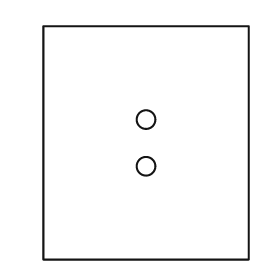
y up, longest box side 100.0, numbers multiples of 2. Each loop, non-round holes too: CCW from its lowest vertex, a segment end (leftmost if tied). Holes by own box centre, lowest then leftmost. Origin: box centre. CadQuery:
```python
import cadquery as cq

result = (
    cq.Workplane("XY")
    .moveTo(-44.0, -50.0)
    .lineTo(44.0, -50.0)
    .lineTo(44.0, 50.0)
    .lineTo(-44.0, 50.0)
    .close()
    .moveTo(0.0, -10.0)
    .circle(4.0)
    .moveTo(0.0, 10.0)
    .circle(4.0)
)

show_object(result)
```